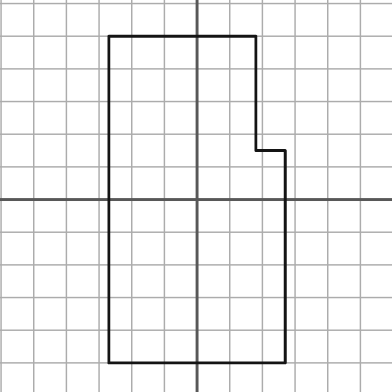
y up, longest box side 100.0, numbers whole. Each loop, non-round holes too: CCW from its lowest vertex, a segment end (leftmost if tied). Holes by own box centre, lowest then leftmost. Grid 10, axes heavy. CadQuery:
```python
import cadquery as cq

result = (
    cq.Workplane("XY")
    .moveTo(-27.0, -50.0)
    .lineTo(27.0, -50.0)
    .lineTo(27.0, 15.0)
    .lineTo(18.0, 15.0)
    .lineTo(18.0, 50.0)
    .lineTo(-27.0, 50.0)
    .close()
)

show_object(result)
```